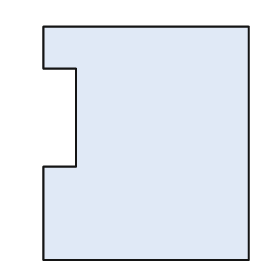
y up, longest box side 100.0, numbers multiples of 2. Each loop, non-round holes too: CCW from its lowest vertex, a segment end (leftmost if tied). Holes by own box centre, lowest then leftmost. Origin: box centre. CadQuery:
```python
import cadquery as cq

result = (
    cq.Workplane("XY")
    .moveTo(-44.0, -50.0)
    .lineTo(44.0, -50.0)
    .lineTo(44.0, 50.0)
    .lineTo(-44.0, 50.0)
    .lineTo(-44.0, 32.0)
    .lineTo(-30.0, 32.0)
    .lineTo(-30.0, -10.0)
    .lineTo(-44.0, -10.0)
    .close()
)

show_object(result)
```